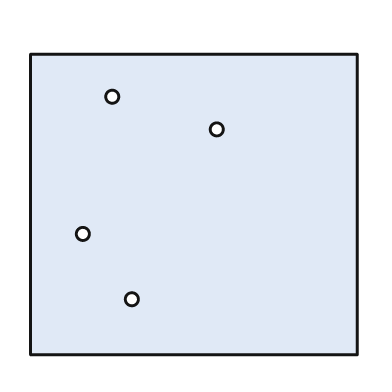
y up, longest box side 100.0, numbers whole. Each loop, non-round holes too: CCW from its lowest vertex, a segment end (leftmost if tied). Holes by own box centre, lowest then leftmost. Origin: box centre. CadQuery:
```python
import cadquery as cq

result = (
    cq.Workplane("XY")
    .moveTo(-50.0, -46.0)
    .lineTo(50.0, -46.0)
    .lineTo(50.0, 46.0)
    .lineTo(-50.0, 46.0)
    .close()
    .moveTo(-19.0, -29.0)
    .circle(2.0)
    .moveTo(-34.0, -9.0)
    .circle(2.0)
    .moveTo(7.0, 23.0)
    .circle(2.0)
    .moveTo(-25.0, 33.0)
    .circle(2.0)
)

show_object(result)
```